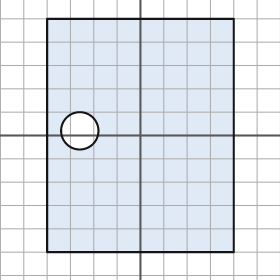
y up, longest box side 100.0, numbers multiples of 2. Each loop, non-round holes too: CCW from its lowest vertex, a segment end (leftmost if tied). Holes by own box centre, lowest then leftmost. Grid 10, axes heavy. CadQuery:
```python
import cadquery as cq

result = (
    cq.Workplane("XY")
    .moveTo(-40.0, -50.0)
    .lineTo(40.0, -50.0)
    .lineTo(40.0, 50.0)
    .lineTo(-40.0, 50.0)
    .close()
    .moveTo(-26.0, 2.0)
    .circle(8.0)
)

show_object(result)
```